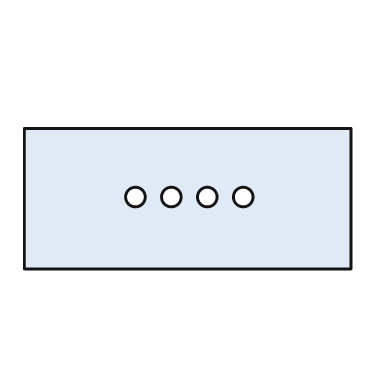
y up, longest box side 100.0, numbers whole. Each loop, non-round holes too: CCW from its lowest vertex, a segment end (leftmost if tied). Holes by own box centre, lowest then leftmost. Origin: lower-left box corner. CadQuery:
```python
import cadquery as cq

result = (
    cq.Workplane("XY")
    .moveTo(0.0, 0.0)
    .lineTo(100.0, 0.0)
    .lineTo(100.0, 43.0)
    .lineTo(0.0, 43.0)
    .close()
    .moveTo(34.0, 22.0)
    .circle(3.0)
    .moveTo(45.0, 22.0)
    .circle(3.0)
    .moveTo(56.0, 22.0)
    .circle(3.0)
    .moveTo(67.0, 22.0)
    .circle(3.0)
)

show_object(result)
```